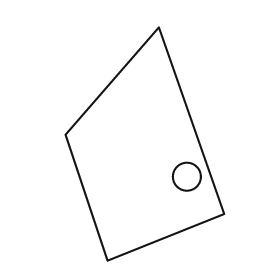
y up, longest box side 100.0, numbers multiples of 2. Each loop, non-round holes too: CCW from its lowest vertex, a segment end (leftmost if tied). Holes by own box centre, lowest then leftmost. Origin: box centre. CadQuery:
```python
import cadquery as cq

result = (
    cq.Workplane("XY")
    .moveTo(-16.0, -50.0)
    .lineTo(34.0, -30.0)
    .lineTo(6.0, 50.0)
    .lineTo(-34.0, 4.0)
    .close()
    .moveTo(18.0, -14.0)
    .circle(6.0)
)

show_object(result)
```